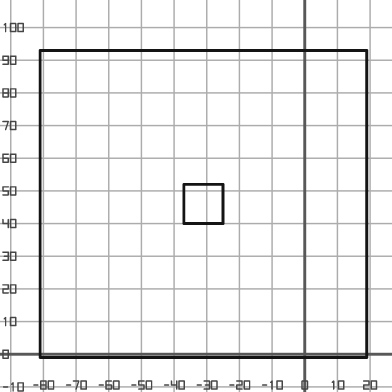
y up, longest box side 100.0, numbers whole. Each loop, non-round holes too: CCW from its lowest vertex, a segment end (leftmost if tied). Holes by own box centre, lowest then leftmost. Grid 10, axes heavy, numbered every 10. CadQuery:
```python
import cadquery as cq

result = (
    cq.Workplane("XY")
    .moveTo(-81.0, -1.0)
    .lineTo(19.0, -1.0)
    .lineTo(19.0, 93.0)
    .lineTo(-81.0, 93.0)
    .close()
    .moveTo(-37.0, 40.0)
    .lineTo(-25.0, 40.0)
    .lineTo(-25.0, 52.0)
    .lineTo(-37.0, 52.0)
    .close()
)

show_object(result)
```